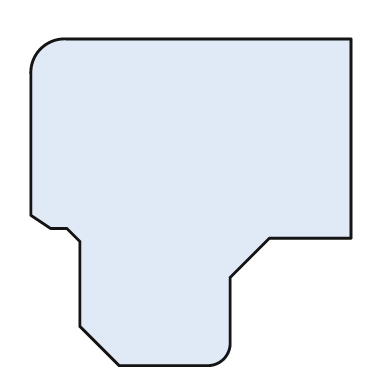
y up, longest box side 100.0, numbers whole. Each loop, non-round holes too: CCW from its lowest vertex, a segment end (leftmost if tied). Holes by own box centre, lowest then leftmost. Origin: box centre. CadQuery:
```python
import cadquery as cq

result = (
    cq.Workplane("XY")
    .moveTo(-22.0, -50.0)
    .lineTo(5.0, -50.0)
    .threePointArc((10.0, -48.0), (12.0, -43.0))
    .lineTo(12.0, -23.0)
    .lineTo(24.0, -11.0)
    .lineTo(49.0, -11.0)
    .lineTo(49.0, 50.0)
    .lineTo(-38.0, 50.0)
    .threePointArc((-46.0, 47.0), (-49.0, 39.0))
    .lineTo(-49.0, -4.0)
    .lineTo(-43.0, -8.0)
    .lineTo(-38.0, -8.0)
    .lineTo(-34.0, -12.0)
    .lineTo(-34.0, -38.0)
    .close()
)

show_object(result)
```